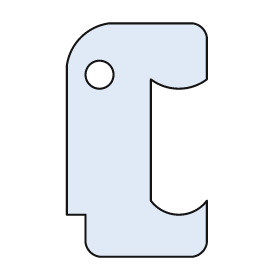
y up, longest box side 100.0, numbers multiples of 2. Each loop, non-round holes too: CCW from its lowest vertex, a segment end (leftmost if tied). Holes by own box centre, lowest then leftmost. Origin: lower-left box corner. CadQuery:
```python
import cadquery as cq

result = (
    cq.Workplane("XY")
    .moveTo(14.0, 0.0)
    .lineTo(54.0, 0.0)
    .threePointArc((58.0, 2.0), (60.0, 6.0))
    .lineTo(60.0, 24.0)
    .threePointArc((48.0, 18.0), (36.0, 24.0))
    .lineTo(36.0, 76.0)
    .threePointArc((48.0, 72.0), (60.0, 76.0))
    .lineTo(60.0, 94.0)
    .threePointArc((58.0, 98.0), (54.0, 100.0))
    .lineTo(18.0, 100.0)
    .threePointArc((6.0, 94.0), (0.0, 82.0))
    .lineTo(0.0, 18.0)
    .lineTo(8.0, 18.0)
    .lineTo(8.0, 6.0)
    .threePointArc((10.0, 2.0), (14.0, 0.0))
    .close()
    .moveTo(14.0, 78.0)
    .circle(6.0)
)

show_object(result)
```